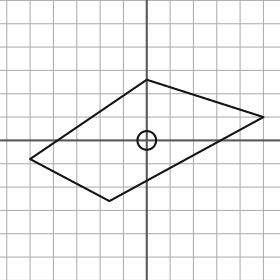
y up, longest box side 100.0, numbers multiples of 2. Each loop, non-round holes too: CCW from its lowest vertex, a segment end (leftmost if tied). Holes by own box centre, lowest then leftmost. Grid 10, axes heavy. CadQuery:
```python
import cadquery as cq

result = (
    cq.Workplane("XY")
    .moveTo(-16.0, -26.0)
    .lineTo(50.0, 10.0)
    .lineTo(0.0, 26.0)
    .lineTo(-50.0, -8.0)
    .close()
    .moveTo(0.0, 0.0)
    .circle(4.0)
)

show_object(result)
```